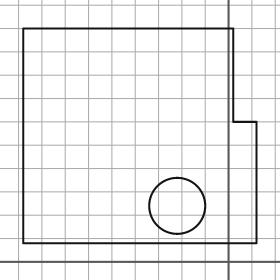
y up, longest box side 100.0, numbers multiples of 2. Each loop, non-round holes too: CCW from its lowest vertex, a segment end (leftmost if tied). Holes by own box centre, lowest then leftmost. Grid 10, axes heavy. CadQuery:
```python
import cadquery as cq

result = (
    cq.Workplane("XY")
    .moveTo(-88.0, 8.0)
    .lineTo(12.0, 8.0)
    .lineTo(12.0, 60.0)
    .lineTo(2.0, 60.0)
    .lineTo(2.0, 100.0)
    .lineTo(-88.0, 100.0)
    .close()
    .moveTo(-22.0, 24.0)
    .circle(12.0)
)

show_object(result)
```